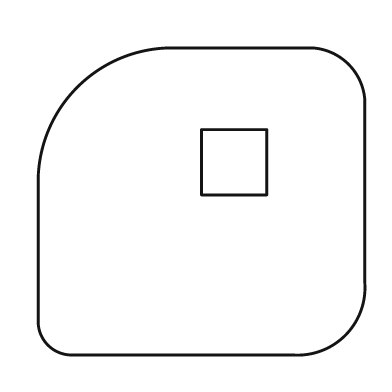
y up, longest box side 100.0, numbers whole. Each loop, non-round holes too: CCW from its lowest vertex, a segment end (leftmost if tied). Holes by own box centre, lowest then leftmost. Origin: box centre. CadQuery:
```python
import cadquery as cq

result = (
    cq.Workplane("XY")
    .moveTo(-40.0, -47.0)
    .lineTo(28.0, -47.0)
    .threePointArc((44.0, -41.0), (50.0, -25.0))
    .lineTo(50.0, 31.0)
    .threePointArc((45.0, 42.0), (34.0, 47.0))
    .lineTo(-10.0, 47.0)
    .threePointArc((-38.0, 35.0), (-50.0, 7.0))
    .lineTo(-50.0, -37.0)
    .threePointArc((-47.0, -44.0), (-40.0, -47.0))
    .close()
    .moveTo(0.0, 2.0)
    .lineTo(20.0, 2.0)
    .lineTo(20.0, 22.0)
    .lineTo(0.0, 22.0)
    .close()
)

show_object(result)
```